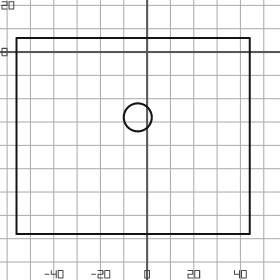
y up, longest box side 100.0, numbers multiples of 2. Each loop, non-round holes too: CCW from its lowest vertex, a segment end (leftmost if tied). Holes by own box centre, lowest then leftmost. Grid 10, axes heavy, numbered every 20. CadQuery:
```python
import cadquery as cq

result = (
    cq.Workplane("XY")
    .moveTo(-56.0, -78.0)
    .lineTo(44.0, -78.0)
    .lineTo(44.0, 6.0)
    .lineTo(-56.0, 6.0)
    .close()
    .moveTo(-4.0, -28.0)
    .circle(6.0)
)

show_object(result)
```